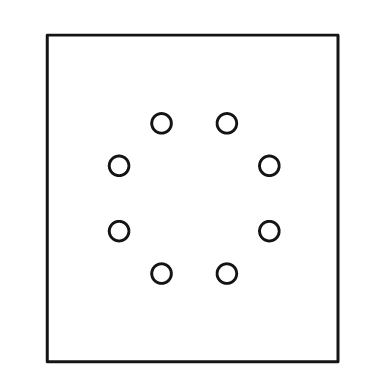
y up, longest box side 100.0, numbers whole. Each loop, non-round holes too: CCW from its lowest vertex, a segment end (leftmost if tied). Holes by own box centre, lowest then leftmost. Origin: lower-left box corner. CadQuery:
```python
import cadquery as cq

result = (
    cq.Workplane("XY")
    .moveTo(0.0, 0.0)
    .lineTo(89.0, 0.0)
    .lineTo(89.0, 100.0)
    .lineTo(0.0, 100.0)
    .close()
    .moveTo(35.0, 27.0)
    .circle(3.0)
    .moveTo(55.0, 27.0)
    .circle(3.0)
    .moveTo(22.0, 40.0)
    .circle(3.0)
    .moveTo(68.0, 40.0)
    .circle(3.0)
    .moveTo(22.0, 60.0)
    .circle(3.0)
    .moveTo(68.0, 60.0)
    .circle(3.0)
    .moveTo(35.0, 73.0)
    .circle(3.0)
    .moveTo(55.0, 73.0)
    .circle(3.0)
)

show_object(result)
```